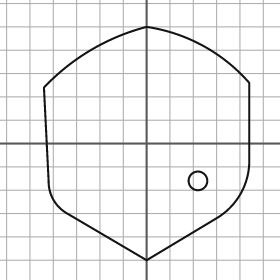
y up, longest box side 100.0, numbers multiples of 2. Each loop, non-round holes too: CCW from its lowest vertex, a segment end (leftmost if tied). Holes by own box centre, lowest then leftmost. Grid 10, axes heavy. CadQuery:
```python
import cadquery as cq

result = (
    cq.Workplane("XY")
    .moveTo(0.0, -50.0)
    .lineTo(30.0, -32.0)
    .threePointArc((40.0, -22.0), (44.0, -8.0))
    .lineTo(44.0, 26.0)
    .threePointArc((24.0, 42.0), (0.0, 50.0))
    .threePointArc((-24.0, 40.0), (-44.0, 24.0))
    .lineTo(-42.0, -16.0)
    .threePointArc((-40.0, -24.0), (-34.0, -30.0))
    .close()
    .moveTo(22.0, -16.0)
    .circle(4.0)
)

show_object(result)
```